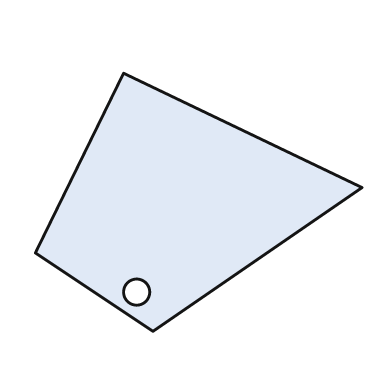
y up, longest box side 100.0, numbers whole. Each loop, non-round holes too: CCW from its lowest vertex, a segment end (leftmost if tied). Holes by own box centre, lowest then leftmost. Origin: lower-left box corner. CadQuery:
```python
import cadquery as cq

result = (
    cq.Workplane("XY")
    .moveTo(36.0, 0.0)
    .lineTo(100.0, 44.0)
    .lineTo(27.0, 79.0)
    .lineTo(0.0, 24.0)
    .close()
    .moveTo(31.0, 12.0)
    .circle(4.0)
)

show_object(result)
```